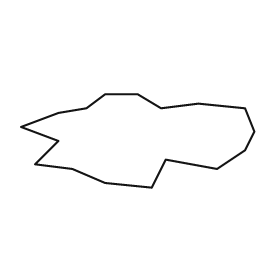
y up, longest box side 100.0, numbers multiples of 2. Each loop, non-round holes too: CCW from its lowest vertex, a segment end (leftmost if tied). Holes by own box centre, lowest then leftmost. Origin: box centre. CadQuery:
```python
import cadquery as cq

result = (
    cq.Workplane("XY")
    .moveTo(6.0, -20.0)
    .lineTo(12.0, -8.0)
    .lineTo(34.0, -12.0)
    .lineTo(46.0, -4.0)
    .lineTo(50.0, 4.0)
    .lineTo(46.0, 14.0)
    .lineTo(26.0, 16.0)
    .lineTo(10.0, 14.0)
    .lineTo(0.0, 20.0)
    .lineTo(-14.0, 20.0)
    .lineTo(-22.0, 14.0)
    .lineTo(-34.0, 12.0)
    .lineTo(-50.0, 6.0)
    .lineTo(-34.0, 0.0)
    .lineTo(-44.0, -10.0)
    .lineTo(-28.0, -12.0)
    .lineTo(-14.0, -18.0)
    .close()
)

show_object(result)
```